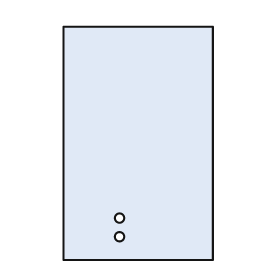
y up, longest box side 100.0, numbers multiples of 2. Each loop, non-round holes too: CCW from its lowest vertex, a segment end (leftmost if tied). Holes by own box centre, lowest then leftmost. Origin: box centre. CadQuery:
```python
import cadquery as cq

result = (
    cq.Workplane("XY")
    .moveTo(-32.0, -50.0)
    .lineTo(32.0, -50.0)
    .lineTo(32.0, 50.0)
    .lineTo(-32.0, 50.0)
    .close()
    .moveTo(-8.0, -40.0)
    .circle(2.0)
    .moveTo(-8.0, -32.0)
    .circle(2.0)
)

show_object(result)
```